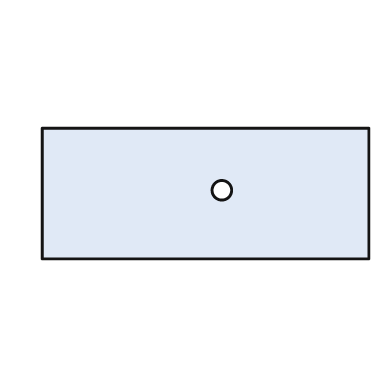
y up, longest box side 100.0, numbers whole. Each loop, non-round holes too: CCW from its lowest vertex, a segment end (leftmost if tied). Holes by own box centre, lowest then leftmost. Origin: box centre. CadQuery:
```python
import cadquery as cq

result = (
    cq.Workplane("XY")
    .moveTo(-50.0, -20.0)
    .lineTo(50.0, -20.0)
    .lineTo(50.0, 20.0)
    .lineTo(-50.0, 20.0)
    .close()
    .moveTo(5.0, 1.0)
    .circle(3.0)
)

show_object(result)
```